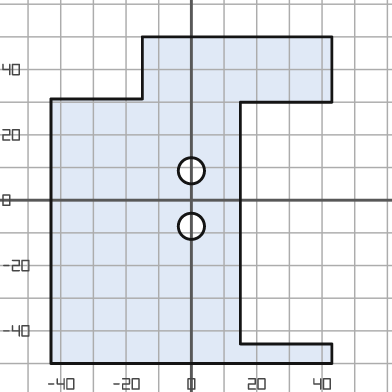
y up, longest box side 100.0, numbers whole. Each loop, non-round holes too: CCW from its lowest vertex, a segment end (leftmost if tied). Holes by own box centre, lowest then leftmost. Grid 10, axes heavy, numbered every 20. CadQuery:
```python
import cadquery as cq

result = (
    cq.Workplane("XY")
    .moveTo(-43.0, -50.0)
    .lineTo(43.0, -50.0)
    .lineTo(43.0, -44.0)
    .lineTo(15.0, -44.0)
    .lineTo(15.0, 30.0)
    .lineTo(43.0, 30.0)
    .lineTo(43.0, 50.0)
    .lineTo(-15.0, 50.0)
    .lineTo(-15.0, 31.0)
    .lineTo(-43.0, 31.0)
    .close()
    .moveTo(0.0, -8.0)
    .circle(4.0)
    .moveTo(0.0, 9.0)
    .circle(4.0)
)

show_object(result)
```